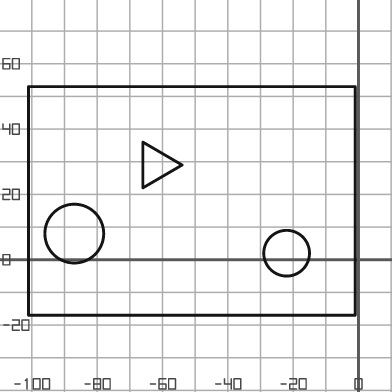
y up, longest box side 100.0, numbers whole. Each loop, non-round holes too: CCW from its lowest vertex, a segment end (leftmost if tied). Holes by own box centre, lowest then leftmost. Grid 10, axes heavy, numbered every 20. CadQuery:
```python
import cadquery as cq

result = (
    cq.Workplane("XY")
    .moveTo(-101.0, -17.0)
    .lineTo(-1.0, -17.0)
    .lineTo(-1.0, 53.0)
    .lineTo(-101.0, 53.0)
    .close()
    .moveTo(-22.0, 2.0)
    .circle(7.0)
    .moveTo(-87.0, 8.0)
    .circle(9.0)
    .moveTo(-66.0, 22.0)
    .lineTo(-54.0, 29.0)
    .lineTo(-66.0, 36.0)
    .close()
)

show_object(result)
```